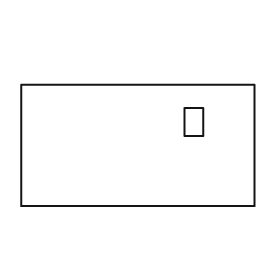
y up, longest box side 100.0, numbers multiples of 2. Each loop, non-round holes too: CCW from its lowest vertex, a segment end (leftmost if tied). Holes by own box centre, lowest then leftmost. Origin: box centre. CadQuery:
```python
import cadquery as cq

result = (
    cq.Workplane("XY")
    .moveTo(-50.0, -26.0)
    .lineTo(50.0, -26.0)
    .lineTo(50.0, 26.0)
    .lineTo(-50.0, 26.0)
    .close()
    .moveTo(20.0, 4.0)
    .lineTo(28.0, 4.0)
    .lineTo(28.0, 16.0)
    .lineTo(20.0, 16.0)
    .close()
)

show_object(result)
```